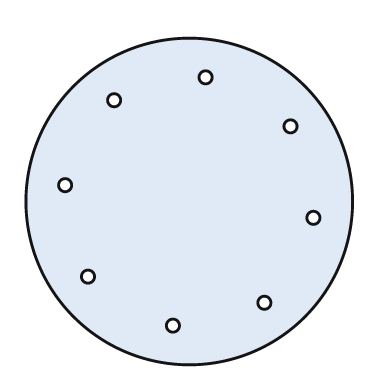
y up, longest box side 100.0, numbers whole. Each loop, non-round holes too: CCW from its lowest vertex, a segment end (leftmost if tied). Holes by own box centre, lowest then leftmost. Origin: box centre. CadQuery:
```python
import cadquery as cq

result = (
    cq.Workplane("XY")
    .moveTo(0.0, 0.0)
    .circle(50.0)
    .moveTo(-5.0, -38.0)
    .circle(2.0)
    .moveTo(23.0, -31.0)
    .circle(2.0)
    .moveTo(-31.0, -23.0)
    .circle(2.0)
    .moveTo(38.0, -5.0)
    .circle(2.0)
    .moveTo(-38.0, 5.0)
    .circle(2.0)
    .moveTo(31.0, 23.0)
    .circle(2.0)
    .moveTo(-23.0, 31.0)
    .circle(2.0)
    .moveTo(5.0, 38.0)
    .circle(2.0)
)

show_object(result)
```